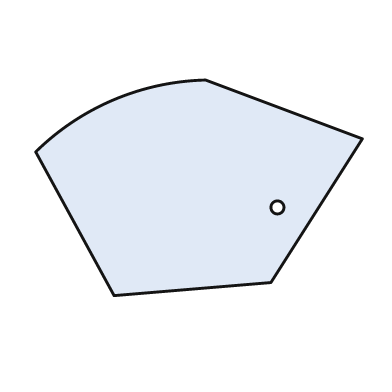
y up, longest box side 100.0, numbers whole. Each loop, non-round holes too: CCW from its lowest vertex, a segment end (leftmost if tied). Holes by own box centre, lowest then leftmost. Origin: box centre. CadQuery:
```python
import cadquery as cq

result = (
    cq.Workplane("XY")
    .moveTo(-26.0, -33.0)
    .lineTo(22.0, -29.0)
    .lineTo(50.0, 15.0)
    .lineTo(2.0, 33.0)
    .threePointArc((-26.0, 27.0), (-50.0, 11.0))
    .close()
    .moveTo(24.0, -6.0)
    .circle(2.0)
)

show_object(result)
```